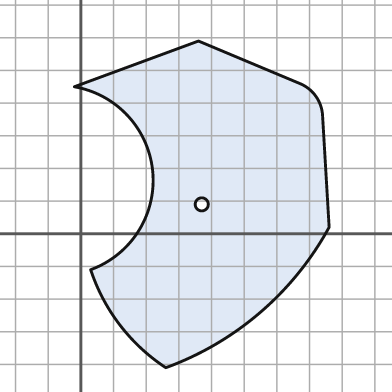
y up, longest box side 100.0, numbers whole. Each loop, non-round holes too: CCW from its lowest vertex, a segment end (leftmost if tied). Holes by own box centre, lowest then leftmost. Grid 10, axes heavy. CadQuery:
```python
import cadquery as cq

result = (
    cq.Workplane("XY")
    .moveTo(26.0, -41.0)
    .threePointArc((55.0, -24.0), (76.0, 2.0))
    .lineTo(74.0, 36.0)
    .threePointArc((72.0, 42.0), (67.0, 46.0))
    .lineTo(36.0, 59.0)
    .lineTo(-2.0, 45.0)
    .threePointArc((22.0, 19.0), (3.0, -11.0))
    .threePointArc((12.0, -28.0), (26.0, -41.0))
    .close()
    .moveTo(37.0, 9.0)
    .circle(2.0)
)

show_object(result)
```